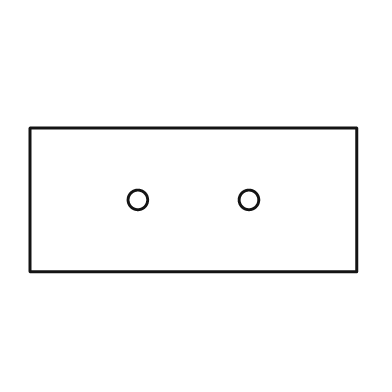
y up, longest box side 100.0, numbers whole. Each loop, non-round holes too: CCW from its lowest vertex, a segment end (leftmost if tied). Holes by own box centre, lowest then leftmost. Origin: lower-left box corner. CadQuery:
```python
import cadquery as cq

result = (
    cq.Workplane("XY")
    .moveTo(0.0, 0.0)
    .lineTo(100.0, 0.0)
    .lineTo(100.0, 44.0)
    .lineTo(0.0, 44.0)
    .close()
    .moveTo(33.0, 22.0)
    .circle(3.0)
    .moveTo(67.0, 22.0)
    .circle(3.0)
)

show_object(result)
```